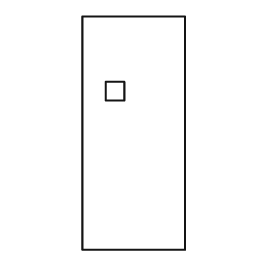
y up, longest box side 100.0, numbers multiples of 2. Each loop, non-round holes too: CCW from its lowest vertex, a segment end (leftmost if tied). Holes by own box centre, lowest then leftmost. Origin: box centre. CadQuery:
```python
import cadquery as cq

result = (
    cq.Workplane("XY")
    .moveTo(-22.0, -50.0)
    .lineTo(22.0, -50.0)
    .lineTo(22.0, 50.0)
    .lineTo(-22.0, 50.0)
    .close()
    .moveTo(-12.0, 14.0)
    .lineTo(-4.0, 14.0)
    .lineTo(-4.0, 22.0)
    .lineTo(-12.0, 22.0)
    .close()
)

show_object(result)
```